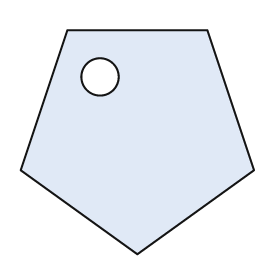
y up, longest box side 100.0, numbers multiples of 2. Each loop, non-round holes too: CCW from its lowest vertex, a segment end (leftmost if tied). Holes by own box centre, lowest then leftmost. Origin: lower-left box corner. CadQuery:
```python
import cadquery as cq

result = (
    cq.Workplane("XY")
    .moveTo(50.0, 0.0)
    .lineTo(100.0, 36.0)
    .lineTo(80.0, 96.0)
    .lineTo(20.0, 96.0)
    .lineTo(0.0, 36.0)
    .close()
    .moveTo(34.0, 76.0)
    .circle(8.0)
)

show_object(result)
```